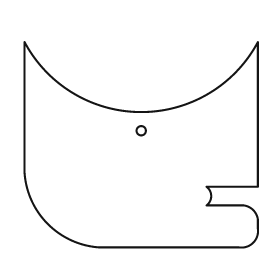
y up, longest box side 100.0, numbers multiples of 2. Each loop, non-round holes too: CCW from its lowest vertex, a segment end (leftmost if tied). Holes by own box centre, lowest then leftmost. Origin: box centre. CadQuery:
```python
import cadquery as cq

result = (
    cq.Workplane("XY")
    .moveTo(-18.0, -44.0)
    .lineTo(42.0, -44.0)
    .threePointArc((48.0, -42.0), (50.0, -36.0))
    .lineTo(50.0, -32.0)
    .threePointArc((48.0, -28.0), (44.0, -26.0))
    .lineTo(28.0, -26.0)
    .threePointArc((30.0, -22.0), (28.0, -18.0))
    .lineTo(50.0, -18.0)
    .lineTo(50.0, 44.0)
    .threePointArc((0.0, 14.0), (-50.0, 44.0))
    .lineTo(-50.0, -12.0)
    .threePointArc((-40.0, -34.0), (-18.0, -44.0))
    .close()
    .moveTo(0.0, 6.0)
    .circle(2.0)
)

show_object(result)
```